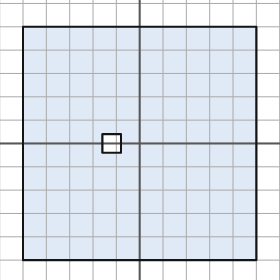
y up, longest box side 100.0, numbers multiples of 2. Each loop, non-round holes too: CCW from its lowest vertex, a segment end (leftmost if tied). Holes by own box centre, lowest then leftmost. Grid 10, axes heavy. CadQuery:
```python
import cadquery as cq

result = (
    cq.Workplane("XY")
    .moveTo(-50.0, -50.0)
    .lineTo(50.0, -50.0)
    .lineTo(50.0, 50.0)
    .lineTo(-50.0, 50.0)
    .close()
    .moveTo(-16.0, -4.0)
    .lineTo(-8.0, -4.0)
    .lineTo(-8.0, 4.0)
    .lineTo(-16.0, 4.0)
    .close()
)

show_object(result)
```